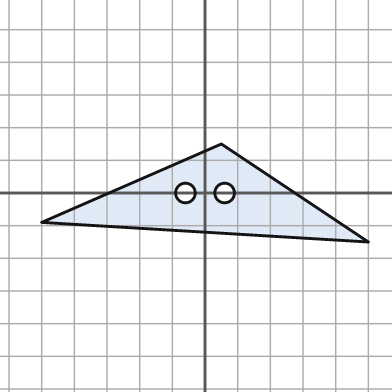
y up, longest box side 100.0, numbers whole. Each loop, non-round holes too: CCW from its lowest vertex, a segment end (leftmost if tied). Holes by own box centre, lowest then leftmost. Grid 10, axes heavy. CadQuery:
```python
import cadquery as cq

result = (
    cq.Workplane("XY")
    .moveTo(50.0, -15.0)
    .lineTo(5.0, 15.0)
    .lineTo(-50.0, -9.0)
    .close()
    .moveTo(-6.0, 0.0)
    .circle(3.0)
    .moveTo(6.0, 0.0)
    .circle(3.0)
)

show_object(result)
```